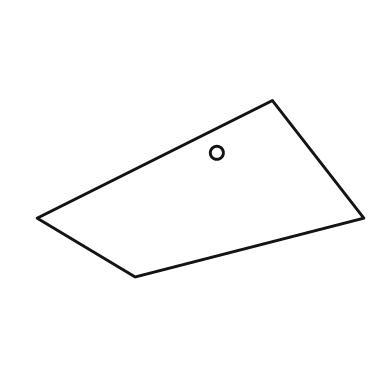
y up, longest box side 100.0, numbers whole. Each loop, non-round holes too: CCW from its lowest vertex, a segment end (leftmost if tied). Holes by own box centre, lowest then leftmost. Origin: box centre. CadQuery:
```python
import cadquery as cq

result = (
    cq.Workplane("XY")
    .moveTo(-20.0, -27.0)
    .lineTo(50.0, -9.0)
    .lineTo(22.0, 27.0)
    .lineTo(-50.0, -9.0)
    .close()
    .moveTo(5.0, 11.0)
    .circle(2.0)
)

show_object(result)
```